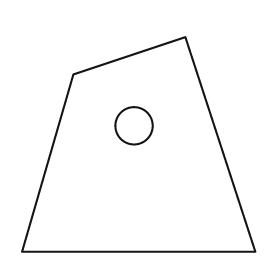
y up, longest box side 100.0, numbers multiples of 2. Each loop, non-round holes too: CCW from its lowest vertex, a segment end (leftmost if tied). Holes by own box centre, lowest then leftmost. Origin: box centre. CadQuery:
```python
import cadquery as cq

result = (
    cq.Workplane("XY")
    .moveTo(-50.0, -46.0)
    .lineTo(50.0, -46.0)
    .lineTo(20.0, 46.0)
    .lineTo(-28.0, 30.0)
    .close()
    .moveTo(-2.0, 8.0)
    .circle(8.0)
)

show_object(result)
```